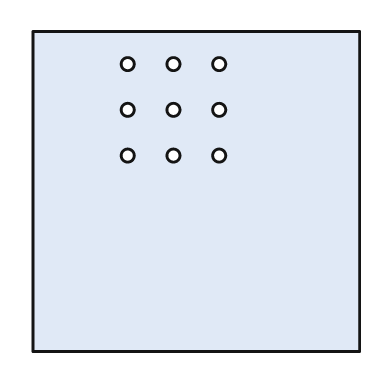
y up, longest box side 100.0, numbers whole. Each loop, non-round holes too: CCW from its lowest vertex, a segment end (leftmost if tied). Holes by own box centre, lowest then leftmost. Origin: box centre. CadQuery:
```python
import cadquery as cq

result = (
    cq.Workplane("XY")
    .moveTo(-50.0, -49.0)
    .lineTo(50.0, -49.0)
    .lineTo(50.0, 49.0)
    .lineTo(-50.0, 49.0)
    .close()
    .moveTo(-21.0, 11.0)
    .circle(2.0)
    .moveTo(-7.0, 11.0)
    .circle(2.0)
    .moveTo(7.0, 11.0)
    .circle(2.0)
    .moveTo(-21.0, 25.0)
    .circle(2.0)
    .moveTo(-7.0, 25.0)
    .circle(2.0)
    .moveTo(7.0, 25.0)
    .circle(2.0)
    .moveTo(-21.0, 39.0)
    .circle(2.0)
    .moveTo(-7.0, 39.0)
    .circle(2.0)
    .moveTo(7.0, 39.0)
    .circle(2.0)
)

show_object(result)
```